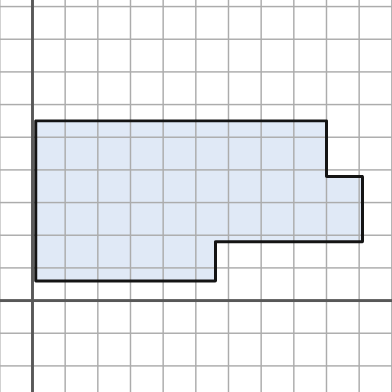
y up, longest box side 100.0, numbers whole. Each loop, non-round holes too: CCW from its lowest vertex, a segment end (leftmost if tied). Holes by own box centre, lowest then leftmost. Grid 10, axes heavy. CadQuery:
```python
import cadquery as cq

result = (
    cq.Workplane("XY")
    .moveTo(1.0, 6.0)
    .lineTo(56.0, 6.0)
    .lineTo(56.0, 18.0)
    .lineTo(101.0, 18.0)
    .lineTo(101.0, 38.0)
    .lineTo(90.0, 38.0)
    .lineTo(90.0, 55.0)
    .lineTo(1.0, 55.0)
    .close()
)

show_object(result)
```